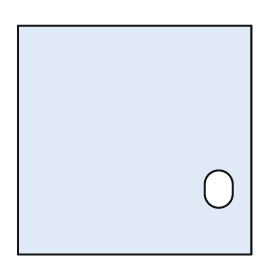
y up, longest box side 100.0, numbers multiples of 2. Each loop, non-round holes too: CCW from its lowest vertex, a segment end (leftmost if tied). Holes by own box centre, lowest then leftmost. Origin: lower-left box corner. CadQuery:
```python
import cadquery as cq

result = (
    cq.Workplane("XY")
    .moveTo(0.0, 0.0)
    .lineTo(100.0, 0.0)
    .lineTo(100.0, 98.0)
    .lineTo(0.0, 98.0)
    .close()
    .moveTo(80.0, 26.0)
    .threePointArc((86.0, 20.0), (92.0, 26.0))
    .lineTo(92.0, 30.0)
    .threePointArc((86.0, 36.0), (80.0, 30.0))
    .close()
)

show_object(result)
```